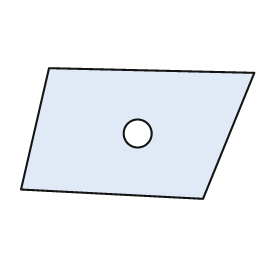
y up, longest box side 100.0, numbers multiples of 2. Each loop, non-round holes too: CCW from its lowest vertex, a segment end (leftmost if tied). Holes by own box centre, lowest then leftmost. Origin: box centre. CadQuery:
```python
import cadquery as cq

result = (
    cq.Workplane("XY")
    .moveTo(28.0, -28.0)
    .lineTo(50.0, 26.0)
    .lineTo(-38.0, 28.0)
    .lineTo(-50.0, -24.0)
    .close()
    .moveTo(0.0, 0.0)
    .circle(6.0)
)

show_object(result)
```